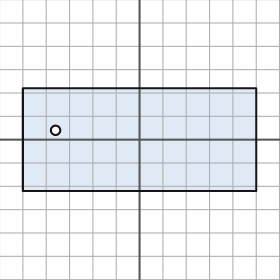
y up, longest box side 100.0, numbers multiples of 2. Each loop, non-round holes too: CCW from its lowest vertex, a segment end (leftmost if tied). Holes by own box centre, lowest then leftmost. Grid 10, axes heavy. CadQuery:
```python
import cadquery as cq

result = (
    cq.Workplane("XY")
    .moveTo(-50.0, -22.0)
    .lineTo(50.0, -22.0)
    .lineTo(50.0, 22.0)
    .lineTo(-50.0, 22.0)
    .close()
    .moveTo(-36.0, 4.0)
    .circle(2.0)
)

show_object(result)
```